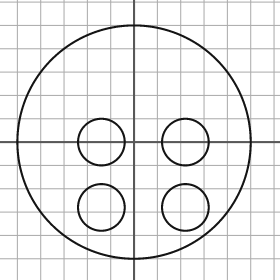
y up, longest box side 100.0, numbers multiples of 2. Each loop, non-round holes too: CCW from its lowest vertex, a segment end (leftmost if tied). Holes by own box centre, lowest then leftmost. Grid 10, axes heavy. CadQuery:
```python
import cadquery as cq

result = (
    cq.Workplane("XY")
    .moveTo(0.0, 0.0)
    .circle(50.0)
    .moveTo(-14.0, -28.0)
    .circle(10.0)
    .moveTo(22.0, -28.0)
    .circle(10.0)
    .moveTo(-14.0, 0.0)
    .circle(10.0)
    .moveTo(22.0, 0.0)
    .circle(10.0)
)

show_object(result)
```